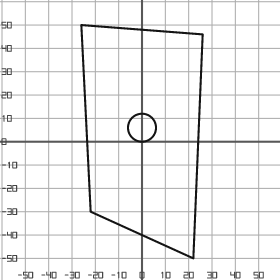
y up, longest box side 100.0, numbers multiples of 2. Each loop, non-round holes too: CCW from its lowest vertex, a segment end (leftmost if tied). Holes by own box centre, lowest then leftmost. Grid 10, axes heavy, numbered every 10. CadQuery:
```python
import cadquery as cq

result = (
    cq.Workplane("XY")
    .moveTo(22.0, -50.0)
    .lineTo(26.0, 46.0)
    .lineTo(-26.0, 50.0)
    .lineTo(-22.0, -30.0)
    .close()
    .moveTo(0.0, 6.0)
    .circle(6.0)
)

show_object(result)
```